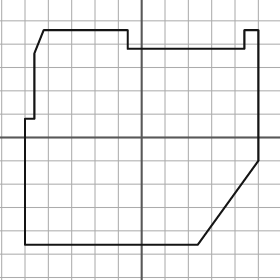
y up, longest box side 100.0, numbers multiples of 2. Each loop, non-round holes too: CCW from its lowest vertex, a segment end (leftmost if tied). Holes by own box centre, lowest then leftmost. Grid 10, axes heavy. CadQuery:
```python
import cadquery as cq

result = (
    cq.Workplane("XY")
    .moveTo(-50.0, -46.0)
    .lineTo(24.0, -46.0)
    .lineTo(50.0, -10.0)
    .lineTo(50.0, 46.0)
    .lineTo(44.0, 46.0)
    .lineTo(44.0, 38.0)
    .lineTo(-6.0, 38.0)
    .lineTo(-6.0, 46.0)
    .lineTo(-42.0, 46.0)
    .lineTo(-46.0, 36.0)
    .lineTo(-46.0, 8.0)
    .lineTo(-50.0, 8.0)
    .close()
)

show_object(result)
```